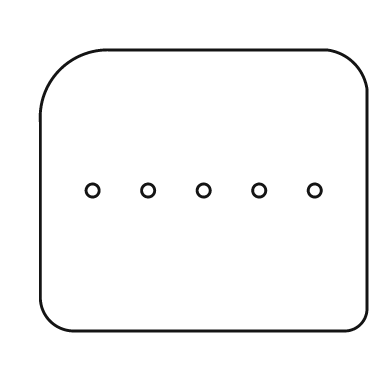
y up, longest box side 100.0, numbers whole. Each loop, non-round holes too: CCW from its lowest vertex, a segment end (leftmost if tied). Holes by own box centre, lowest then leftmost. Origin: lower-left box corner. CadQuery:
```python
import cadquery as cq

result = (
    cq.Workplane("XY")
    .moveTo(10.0, 0.0)
    .lineTo(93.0, 0.0)
    .threePointArc((98.0, 2.0), (100.0, 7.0))
    .lineTo(100.0, 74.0)
    .threePointArc((96.0, 82.0), (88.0, 86.0))
    .lineTo(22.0, 86.0)
    .threePointArc((6.0, 80.0), (0.0, 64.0))
    .lineTo(0.0, 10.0)
    .threePointArc((3.0, 3.0), (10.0, 0.0))
    .close()
    .moveTo(16.0, 43.0)
    .circle(2.0)
    .moveTo(33.0, 43.0)
    .circle(2.0)
    .moveTo(50.0, 43.0)
    .circle(2.0)
    .moveTo(67.0, 43.0)
    .circle(2.0)
    .moveTo(84.0, 43.0)
    .circle(2.0)
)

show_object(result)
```